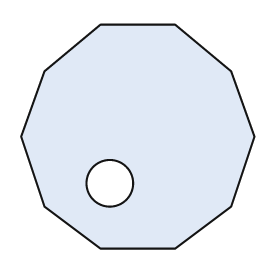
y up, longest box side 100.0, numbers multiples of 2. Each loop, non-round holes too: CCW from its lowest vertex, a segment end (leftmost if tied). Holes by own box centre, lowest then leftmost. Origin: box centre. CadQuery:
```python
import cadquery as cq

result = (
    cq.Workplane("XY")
    .moveTo(-16.0, -48.0)
    .lineTo(16.0, -48.0)
    .lineTo(40.0, -30.0)
    .lineTo(50.0, 0.0)
    .lineTo(40.0, 28.0)
    .lineTo(16.0, 48.0)
    .lineTo(-16.0, 48.0)
    .lineTo(-40.0, 28.0)
    .lineTo(-50.0, 0.0)
    .lineTo(-40.0, -30.0)
    .close()
    .moveTo(-12.0, -20.0)
    .circle(10.0)
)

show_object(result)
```